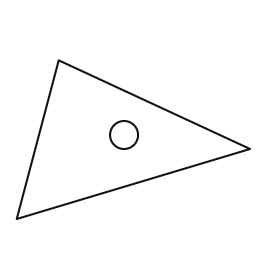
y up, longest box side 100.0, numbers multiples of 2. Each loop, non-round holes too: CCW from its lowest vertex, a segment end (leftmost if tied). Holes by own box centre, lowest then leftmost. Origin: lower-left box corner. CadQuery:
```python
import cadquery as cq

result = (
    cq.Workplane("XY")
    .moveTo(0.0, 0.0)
    .lineTo(100.0, 30.0)
    .lineTo(18.0, 68.0)
    .close()
    .moveTo(46.0, 36.0)
    .circle(6.0)
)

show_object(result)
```